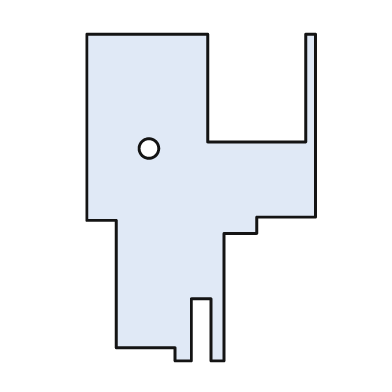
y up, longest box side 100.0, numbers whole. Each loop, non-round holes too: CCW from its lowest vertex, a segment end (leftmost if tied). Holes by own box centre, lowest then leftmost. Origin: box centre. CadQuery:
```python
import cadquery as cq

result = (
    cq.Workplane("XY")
    .moveTo(-8.0, -50.0)
    .lineTo(-3.0, -50.0)
    .lineTo(-3.0, -31.0)
    .lineTo(3.0, -31.0)
    .lineTo(3.0, -50.0)
    .lineTo(7.0, -50.0)
    .lineTo(7.0, -11.0)
    .lineTo(17.0, -11.0)
    .lineTo(17.0, -6.0)
    .lineTo(35.0, -6.0)
    .lineTo(35.0, 50.0)
    .lineTo(32.0, 50.0)
    .lineTo(32.0, 17.0)
    .lineTo(2.0, 17.0)
    .lineTo(2.0, 50.0)
    .lineTo(-35.0, 50.0)
    .lineTo(-35.0, -7.0)
    .lineTo(-26.0, -7.0)
    .lineTo(-26.0, -46.0)
    .lineTo(-8.0, -46.0)
    .close()
    .moveTo(-16.0, 15.0)
    .circle(3.0)
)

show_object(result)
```